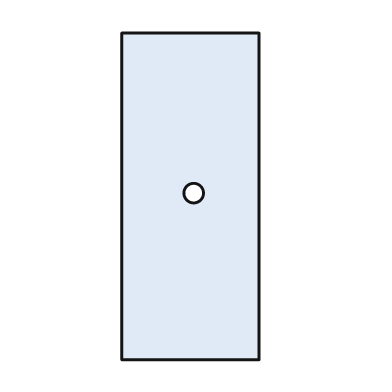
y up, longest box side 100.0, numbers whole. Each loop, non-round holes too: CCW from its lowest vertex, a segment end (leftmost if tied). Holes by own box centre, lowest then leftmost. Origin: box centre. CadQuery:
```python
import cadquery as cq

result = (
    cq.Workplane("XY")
    .moveTo(-21.0, -50.0)
    .lineTo(21.0, -50.0)
    .lineTo(21.0, 50.0)
    .lineTo(-21.0, 50.0)
    .close()
    .moveTo(1.0, 1.0)
    .circle(3.0)
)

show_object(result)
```